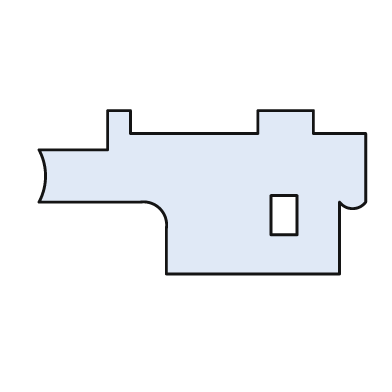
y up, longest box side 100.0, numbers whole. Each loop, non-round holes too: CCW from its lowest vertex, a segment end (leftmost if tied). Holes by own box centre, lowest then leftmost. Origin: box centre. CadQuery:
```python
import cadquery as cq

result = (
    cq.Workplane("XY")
    .moveTo(-11.0, -25.0)
    .lineTo(42.0, -25.0)
    .lineTo(42.0, -3.0)
    .threePointArc((46.0, -5.0), (50.0, -3.0))
    .lineTo(50.0, 18.0)
    .lineTo(34.0, 18.0)
    .lineTo(34.0, 25.0)
    .lineTo(17.0, 25.0)
    .lineTo(17.0, 18.0)
    .lineTo(-22.0, 18.0)
    .lineTo(-22.0, 25.0)
    .lineTo(-29.0, 25.0)
    .lineTo(-29.0, 13.0)
    .lineTo(-50.0, 13.0)
    .threePointArc((-48.0, 5.0), (-50.0, -3.0))
    .lineTo(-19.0, -3.0)
    .threePointArc((-13.0, -5.0), (-11.0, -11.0))
    .close()
    .moveTo(21.0, -13.0)
    .lineTo(29.0, -13.0)
    .lineTo(29.0, -1.0)
    .lineTo(21.0, -1.0)
    .close()
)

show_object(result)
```